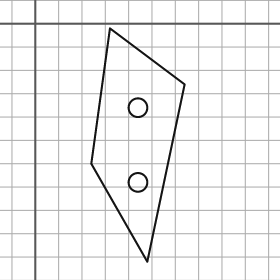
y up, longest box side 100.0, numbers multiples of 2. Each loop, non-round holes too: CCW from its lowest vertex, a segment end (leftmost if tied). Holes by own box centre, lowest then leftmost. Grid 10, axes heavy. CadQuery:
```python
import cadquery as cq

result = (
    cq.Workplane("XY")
    .moveTo(48.0, -102.0)
    .lineTo(64.0, -26.0)
    .lineTo(32.0, -2.0)
    .lineTo(24.0, -60.0)
    .close()
    .moveTo(44.0, -68.0)
    .circle(4.0)
    .moveTo(44.0, -36.0)
    .circle(4.0)
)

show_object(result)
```